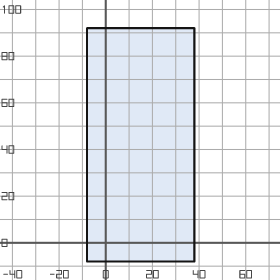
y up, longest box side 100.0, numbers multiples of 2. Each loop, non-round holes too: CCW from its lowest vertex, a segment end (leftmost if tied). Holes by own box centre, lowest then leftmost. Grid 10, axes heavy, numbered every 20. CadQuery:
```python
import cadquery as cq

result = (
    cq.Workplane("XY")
    .moveTo(-8.0, -8.0)
    .lineTo(38.0, -8.0)
    .lineTo(38.0, 92.0)
    .lineTo(-8.0, 92.0)
    .close()
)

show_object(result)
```